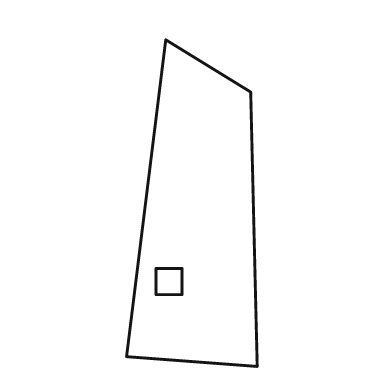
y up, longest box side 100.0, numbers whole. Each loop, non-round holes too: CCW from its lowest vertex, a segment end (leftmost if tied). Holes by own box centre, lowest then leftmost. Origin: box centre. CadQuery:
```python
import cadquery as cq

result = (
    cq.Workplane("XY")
    .moveTo(20.0, -50.0)
    .lineTo(18.0, 34.0)
    .lineTo(-8.0, 50.0)
    .lineTo(-20.0, -47.0)
    .close()
    .moveTo(-11.0, -28.0)
    .lineTo(-3.0, -28.0)
    .lineTo(-3.0, -20.0)
    .lineTo(-11.0, -20.0)
    .close()
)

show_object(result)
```